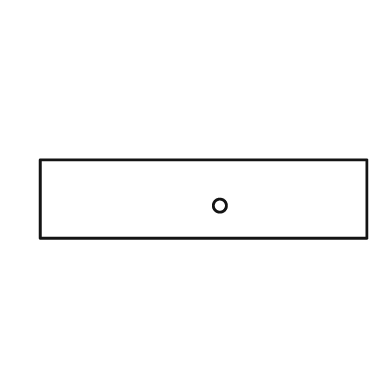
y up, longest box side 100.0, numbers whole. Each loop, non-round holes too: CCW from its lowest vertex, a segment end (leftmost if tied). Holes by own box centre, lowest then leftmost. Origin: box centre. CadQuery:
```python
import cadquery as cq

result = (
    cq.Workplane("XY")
    .moveTo(-50.0, -12.0)
    .lineTo(50.0, -12.0)
    .lineTo(50.0, 12.0)
    .lineTo(-50.0, 12.0)
    .close()
    .moveTo(5.0, -2.0)
    .circle(2.0)
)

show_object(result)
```